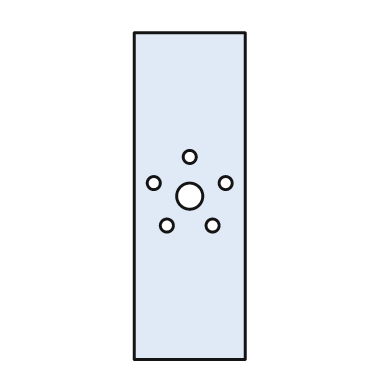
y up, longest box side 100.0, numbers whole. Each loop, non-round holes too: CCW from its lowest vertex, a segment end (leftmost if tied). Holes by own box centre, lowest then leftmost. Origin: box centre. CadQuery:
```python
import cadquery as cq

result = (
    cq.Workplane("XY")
    .moveTo(-17.0, -50.0)
    .lineTo(17.0, -50.0)
    .lineTo(17.0, 50.0)
    .lineTo(-17.0, 50.0)
    .close()
    .moveTo(-7.0, -9.0)
    .circle(2.0)
    .moveTo(7.0, -9.0)
    .circle(2.0)
    .moveTo(0.0, 0.0)
    .circle(4.0)
    .moveTo(-11.0, 4.0)
    .circle(2.0)
    .moveTo(11.0, 4.0)
    .circle(2.0)
    .moveTo(0.0, 12.0)
    .circle(2.0)
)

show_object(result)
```